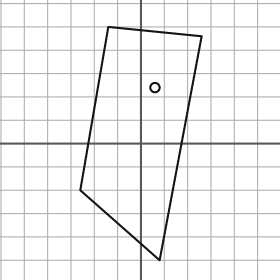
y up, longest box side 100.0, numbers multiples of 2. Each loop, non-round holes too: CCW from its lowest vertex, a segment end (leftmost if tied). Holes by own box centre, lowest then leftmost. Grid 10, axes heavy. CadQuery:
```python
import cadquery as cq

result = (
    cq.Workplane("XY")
    .moveTo(8.0, -50.0)
    .lineTo(26.0, 46.0)
    .lineTo(-14.0, 50.0)
    .lineTo(-26.0, -20.0)
    .close()
    .moveTo(6.0, 24.0)
    .circle(2.0)
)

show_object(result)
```